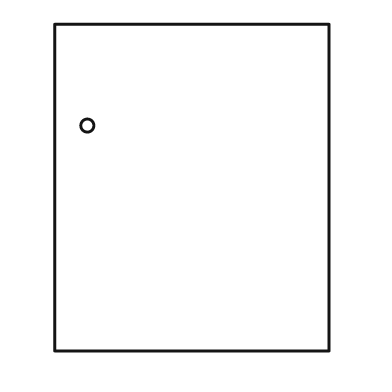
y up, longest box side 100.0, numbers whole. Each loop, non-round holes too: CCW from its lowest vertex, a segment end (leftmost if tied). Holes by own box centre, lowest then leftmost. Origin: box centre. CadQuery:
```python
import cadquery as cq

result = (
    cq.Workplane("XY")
    .moveTo(-42.0, -50.0)
    .lineTo(42.0, -50.0)
    .lineTo(42.0, 50.0)
    .lineTo(-42.0, 50.0)
    .close()
    .moveTo(-32.0, 19.0)
    .circle(2.0)
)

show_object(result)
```